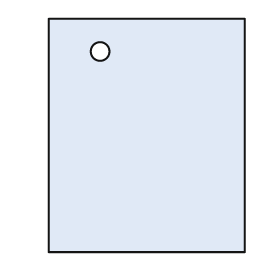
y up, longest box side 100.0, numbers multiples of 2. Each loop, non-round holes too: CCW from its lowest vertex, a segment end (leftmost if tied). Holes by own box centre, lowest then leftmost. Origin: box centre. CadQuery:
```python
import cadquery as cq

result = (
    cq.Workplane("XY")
    .moveTo(-42.0, -50.0)
    .lineTo(42.0, -50.0)
    .lineTo(42.0, 50.0)
    .lineTo(-42.0, 50.0)
    .close()
    .moveTo(-20.0, 36.0)
    .circle(4.0)
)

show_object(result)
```